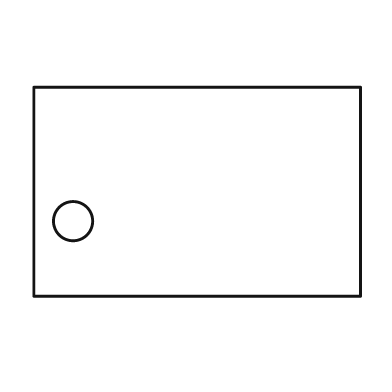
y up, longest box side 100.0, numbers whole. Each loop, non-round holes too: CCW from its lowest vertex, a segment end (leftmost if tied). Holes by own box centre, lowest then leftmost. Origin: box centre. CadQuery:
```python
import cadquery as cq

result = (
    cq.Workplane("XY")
    .moveTo(-50.0, -32.0)
    .lineTo(50.0, -32.0)
    .lineTo(50.0, 32.0)
    .lineTo(-50.0, 32.0)
    .close()
    .moveTo(-38.0, -9.0)
    .circle(6.0)
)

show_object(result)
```